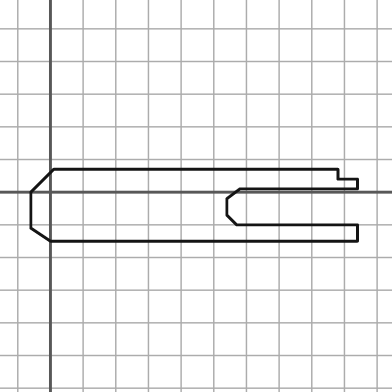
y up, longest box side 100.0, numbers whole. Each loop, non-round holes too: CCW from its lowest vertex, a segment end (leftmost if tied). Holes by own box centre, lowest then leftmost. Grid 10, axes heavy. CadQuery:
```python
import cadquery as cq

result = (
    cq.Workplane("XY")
    .moveTo(0.0, -15.0)
    .lineTo(94.0, -15.0)
    .lineTo(94.0, -10.0)
    .lineTo(57.0, -10.0)
    .lineTo(54.0, -7.0)
    .lineTo(54.0, -2.0)
    .lineTo(58.0, 1.0)
    .lineTo(94.0, 1.0)
    .lineTo(94.0, 4.0)
    .lineTo(88.0, 4.0)
    .lineTo(88.0, 7.0)
    .lineTo(1.0, 7.0)
    .lineTo(-6.0, 0.0)
    .lineTo(-6.0, -11.0)
    .close()
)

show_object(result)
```